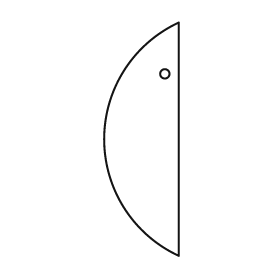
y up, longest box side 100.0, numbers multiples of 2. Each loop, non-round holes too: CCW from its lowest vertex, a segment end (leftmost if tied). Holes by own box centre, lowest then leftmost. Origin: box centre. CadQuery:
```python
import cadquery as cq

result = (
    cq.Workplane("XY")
    .moveTo(16.0, -50.0)
    .lineTo(16.0, 50.0)
    .threePointArc((-16.0, 0.0), (16.0, -50.0))
    .close()
    .moveTo(10.0, 28.0)
    .circle(2.0)
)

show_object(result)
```